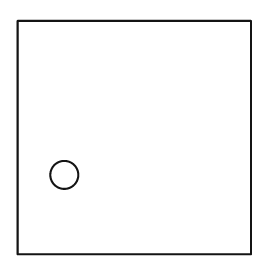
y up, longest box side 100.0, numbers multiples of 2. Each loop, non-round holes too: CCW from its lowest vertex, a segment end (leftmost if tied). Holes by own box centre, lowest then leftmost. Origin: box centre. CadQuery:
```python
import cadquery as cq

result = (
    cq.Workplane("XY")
    .moveTo(-50.0, -50.0)
    .lineTo(50.0, -50.0)
    .lineTo(50.0, 50.0)
    .lineTo(-50.0, 50.0)
    .close()
    .moveTo(-30.0, -16.0)
    .circle(6.0)
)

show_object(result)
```